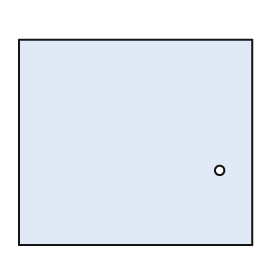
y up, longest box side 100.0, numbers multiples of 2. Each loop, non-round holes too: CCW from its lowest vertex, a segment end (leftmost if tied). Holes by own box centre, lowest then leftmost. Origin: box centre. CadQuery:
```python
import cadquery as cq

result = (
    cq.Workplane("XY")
    .moveTo(-50.0, -44.0)
    .lineTo(50.0, -44.0)
    .lineTo(50.0, 44.0)
    .lineTo(-50.0, 44.0)
    .close()
    .moveTo(36.0, -12.0)
    .circle(2.0)
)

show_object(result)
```